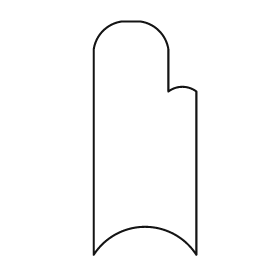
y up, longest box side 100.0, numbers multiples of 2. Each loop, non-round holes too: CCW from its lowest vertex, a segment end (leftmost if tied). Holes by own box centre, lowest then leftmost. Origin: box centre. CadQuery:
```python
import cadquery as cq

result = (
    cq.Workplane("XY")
    .moveTo(-22.0, -50.0)
    .threePointArc((0.0, -38.0), (22.0, -50.0))
    .lineTo(22.0, 20.0)
    .threePointArc((16.0, 22.0), (10.0, 20.0))
    .lineTo(10.0, 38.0)
    .threePointArc((6.0, 46.0), (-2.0, 50.0))
    .lineTo(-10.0, 50.0)
    .threePointArc((-18.0, 46.0), (-22.0, 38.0))
    .close()
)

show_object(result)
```